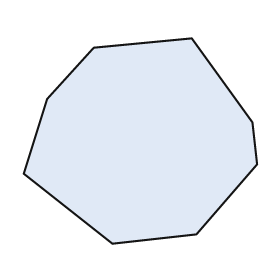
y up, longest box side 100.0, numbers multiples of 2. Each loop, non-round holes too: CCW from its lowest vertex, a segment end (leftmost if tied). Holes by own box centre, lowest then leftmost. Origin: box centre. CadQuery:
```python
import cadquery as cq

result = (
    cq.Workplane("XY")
    .moveTo(-12.0, -44.0)
    .lineTo(24.0, -40.0)
    .lineTo(50.0, -10.0)
    .lineTo(48.0, 8.0)
    .lineTo(22.0, 44.0)
    .lineTo(-20.0, 40.0)
    .lineTo(-40.0, 18.0)
    .lineTo(-50.0, -14.0)
    .close()
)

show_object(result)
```